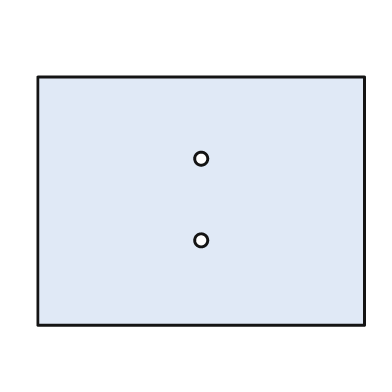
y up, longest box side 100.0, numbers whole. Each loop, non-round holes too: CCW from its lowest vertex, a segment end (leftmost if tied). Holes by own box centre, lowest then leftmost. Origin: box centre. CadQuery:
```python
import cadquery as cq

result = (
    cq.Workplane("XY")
    .moveTo(-50.0, -38.0)
    .lineTo(50.0, -38.0)
    .lineTo(50.0, 38.0)
    .lineTo(-50.0, 38.0)
    .close()
    .moveTo(0.0, -12.0)
    .circle(2.0)
    .moveTo(0.0, 13.0)
    .circle(2.0)
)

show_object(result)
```